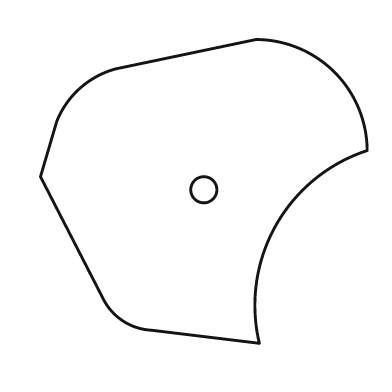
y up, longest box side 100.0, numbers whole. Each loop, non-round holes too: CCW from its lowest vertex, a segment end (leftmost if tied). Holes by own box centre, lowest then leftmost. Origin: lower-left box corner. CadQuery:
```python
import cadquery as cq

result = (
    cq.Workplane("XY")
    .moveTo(67.0, 0.0)
    .threePointArc((72.0, 36.0), (100.0, 59.0))
    .threePointArc((90.0, 83.0), (66.0, 93.0))
    .lineTo(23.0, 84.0)
    .threePointArc((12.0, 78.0), (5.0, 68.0))
    .lineTo(0.0, 51.0)
    .lineTo(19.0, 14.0)
    .threePointArc((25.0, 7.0), (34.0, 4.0))
    .close()
    .moveTo(50.0, 47.0)
    .circle(4.0)
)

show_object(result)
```